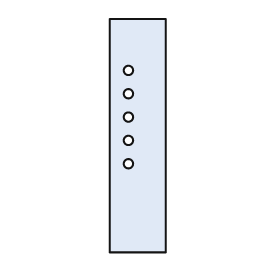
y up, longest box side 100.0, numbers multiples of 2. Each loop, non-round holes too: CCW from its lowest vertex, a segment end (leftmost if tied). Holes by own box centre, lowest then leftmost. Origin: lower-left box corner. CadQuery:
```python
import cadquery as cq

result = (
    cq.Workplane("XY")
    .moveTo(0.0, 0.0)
    .lineTo(24.0, 0.0)
    .lineTo(24.0, 100.0)
    .lineTo(0.0, 100.0)
    .close()
    .moveTo(8.0, 38.0)
    .circle(2.0)
    .moveTo(8.0, 48.0)
    .circle(2.0)
    .moveTo(8.0, 58.0)
    .circle(2.0)
    .moveTo(8.0, 68.0)
    .circle(2.0)
    .moveTo(8.0, 78.0)
    .circle(2.0)
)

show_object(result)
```